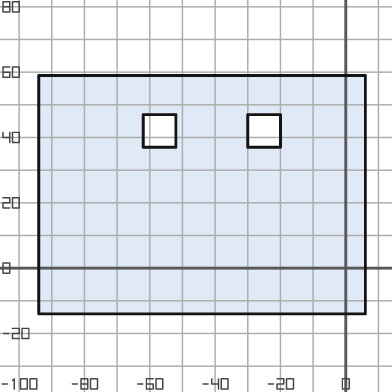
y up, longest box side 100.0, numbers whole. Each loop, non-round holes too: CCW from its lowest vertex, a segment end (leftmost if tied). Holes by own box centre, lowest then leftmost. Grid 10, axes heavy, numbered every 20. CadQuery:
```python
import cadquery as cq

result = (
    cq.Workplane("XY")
    .moveTo(-94.0, -14.0)
    .lineTo(6.0, -14.0)
    .lineTo(6.0, 59.0)
    .lineTo(-94.0, 59.0)
    .close()
    .moveTo(-62.0, 37.0)
    .lineTo(-52.0, 37.0)
    .lineTo(-52.0, 47.0)
    .lineTo(-62.0, 47.0)
    .close()
    .moveTo(-30.0, 37.0)
    .lineTo(-20.0, 37.0)
    .lineTo(-20.0, 47.0)
    .lineTo(-30.0, 47.0)
    .close()
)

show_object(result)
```